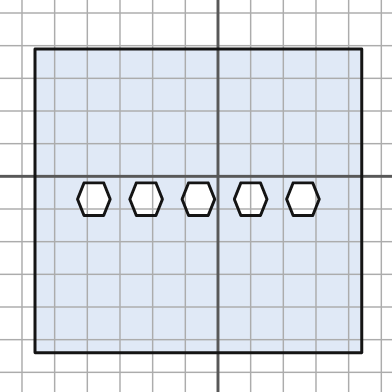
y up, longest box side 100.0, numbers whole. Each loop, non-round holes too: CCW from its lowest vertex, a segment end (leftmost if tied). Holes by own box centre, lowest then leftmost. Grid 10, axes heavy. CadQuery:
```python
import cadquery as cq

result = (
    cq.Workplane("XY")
    .moveTo(-56.0, -54.0)
    .lineTo(44.0, -54.0)
    .lineTo(44.0, 39.0)
    .lineTo(-56.0, 39.0)
    .close()
    .moveTo(-41.0, -12.0)
    .lineTo(-35.0, -12.0)
    .lineTo(-33.0, -7.0)
    .lineTo(-35.0, -2.0)
    .lineTo(-41.0, -2.0)
    .lineTo(-43.0, -7.0)
    .close()
    .moveTo(-25.0, -12.0)
    .lineTo(-19.0, -12.0)
    .lineTo(-17.0, -7.0)
    .lineTo(-19.0, -2.0)
    .lineTo(-25.0, -2.0)
    .lineTo(-27.0, -7.0)
    .close()
    .moveTo(-9.0, -12.0)
    .lineTo(-3.0, -12.0)
    .lineTo(-1.0, -7.0)
    .lineTo(-3.0, -2.0)
    .lineTo(-9.0, -2.0)
    .lineTo(-11.0, -7.0)
    .close()
    .moveTo(7.0, -12.0)
    .lineTo(13.0, -12.0)
    .lineTo(15.0, -7.0)
    .lineTo(13.0, -2.0)
    .lineTo(7.0, -2.0)
    .lineTo(5.0, -7.0)
    .close()
    .moveTo(23.0, -12.0)
    .lineTo(29.0, -12.0)
    .lineTo(31.0, -7.0)
    .lineTo(29.0, -2.0)
    .lineTo(23.0, -2.0)
    .lineTo(21.0, -7.0)
    .close()
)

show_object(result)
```